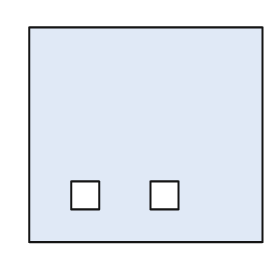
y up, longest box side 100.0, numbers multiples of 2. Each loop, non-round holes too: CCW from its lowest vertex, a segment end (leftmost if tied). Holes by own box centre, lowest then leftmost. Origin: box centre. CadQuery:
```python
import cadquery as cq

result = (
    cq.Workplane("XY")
    .moveTo(-50.0, -46.0)
    .lineTo(50.0, -46.0)
    .lineTo(50.0, 46.0)
    .lineTo(-50.0, 46.0)
    .close()
    .moveTo(-32.0, -32.0)
    .lineTo(-20.0, -32.0)
    .lineTo(-20.0, -20.0)
    .lineTo(-32.0, -20.0)
    .close()
    .moveTo(2.0, -32.0)
    .lineTo(14.0, -32.0)
    .lineTo(14.0, -20.0)
    .lineTo(2.0, -20.0)
    .close()
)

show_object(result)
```